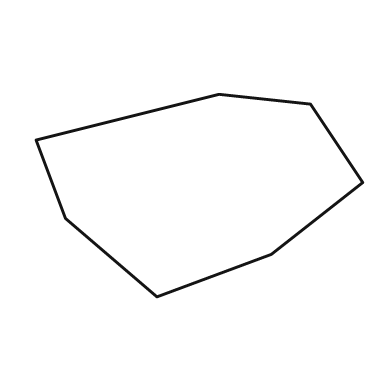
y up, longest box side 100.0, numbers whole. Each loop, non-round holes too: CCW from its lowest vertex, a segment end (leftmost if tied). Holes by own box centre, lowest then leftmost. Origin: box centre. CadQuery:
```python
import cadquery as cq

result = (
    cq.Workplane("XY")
    .moveTo(-13.0, -31.0)
    .lineTo(22.0, -18.0)
    .lineTo(50.0, 4.0)
    .lineTo(34.0, 28.0)
    .lineTo(6.0, 31.0)
    .lineTo(-50.0, 17.0)
    .lineTo(-41.0, -7.0)
    .close()
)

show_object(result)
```